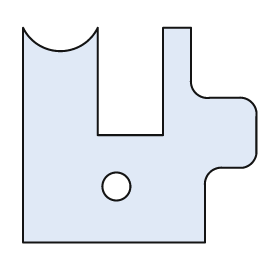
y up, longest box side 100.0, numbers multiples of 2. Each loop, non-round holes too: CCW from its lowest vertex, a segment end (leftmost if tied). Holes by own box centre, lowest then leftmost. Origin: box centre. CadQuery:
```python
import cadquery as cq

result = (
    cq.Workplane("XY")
    .moveTo(-50.0, -46.0)
    .lineTo(28.0, -46.0)
    .lineTo(28.0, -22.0)
    .threePointArc((30.0, -16.0), (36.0, -14.0))
    .lineTo(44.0, -14.0)
    .threePointArc((48.0, -12.0), (50.0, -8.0))
    .lineTo(50.0, 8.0)
    .threePointArc((48.0, 14.0), (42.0, 16.0))
    .lineTo(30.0, 16.0)
    .threePointArc((24.0, 18.0), (22.0, 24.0))
    .lineTo(22.0, 46.0)
    .lineTo(10.0, 46.0)
    .lineTo(10.0, 0.0)
    .lineTo(-18.0, 0.0)
    .lineTo(-18.0, 46.0)
    .threePointArc((-34.0, 36.0), (-50.0, 46.0))
    .close()
    .moveTo(-10.0, -22.0)
    .circle(6.0)
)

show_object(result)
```